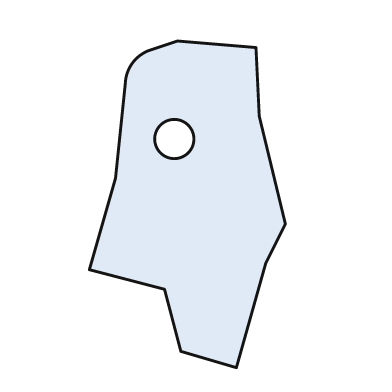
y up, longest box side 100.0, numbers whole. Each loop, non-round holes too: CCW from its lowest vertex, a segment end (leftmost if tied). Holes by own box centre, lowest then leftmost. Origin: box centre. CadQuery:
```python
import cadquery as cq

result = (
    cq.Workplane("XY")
    .moveTo(15.0, -50.0)
    .lineTo(24.0, -18.0)
    .lineTo(30.0, -6.0)
    .lineTo(22.0, 27.0)
    .lineTo(21.0, 48.0)
    .lineTo(-3.0, 50.0)
    .lineTo(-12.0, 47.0)
    .threePointArc((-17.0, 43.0), (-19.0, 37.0))
    .lineTo(-22.0, 8.0)
    .lineTo(-30.0, -20.0)
    .lineTo(-7.0, -26.0)
    .lineTo(-2.0, -45.0)
    .close()
    .moveTo(-4.0, 20.0)
    .circle(6.0)
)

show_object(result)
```